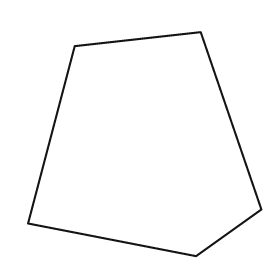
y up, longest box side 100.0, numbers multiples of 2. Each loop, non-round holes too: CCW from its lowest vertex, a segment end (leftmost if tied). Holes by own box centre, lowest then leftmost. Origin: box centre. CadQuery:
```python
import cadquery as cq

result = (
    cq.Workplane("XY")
    .moveTo(22.0, -48.0)
    .lineTo(50.0, -28.0)
    .lineTo(24.0, 48.0)
    .lineTo(-30.0, 42.0)
    .lineTo(-50.0, -34.0)
    .close()
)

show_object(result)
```